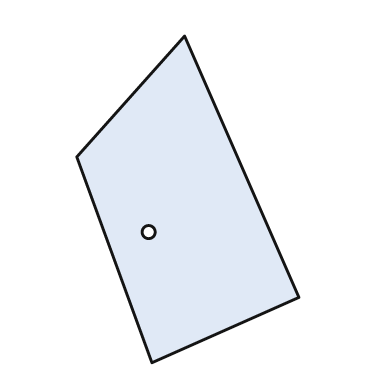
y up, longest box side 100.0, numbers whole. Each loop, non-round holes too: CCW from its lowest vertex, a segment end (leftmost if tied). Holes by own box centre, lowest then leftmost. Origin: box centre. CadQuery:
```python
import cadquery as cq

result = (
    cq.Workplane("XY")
    .moveTo(-11.0, -50.0)
    .lineTo(34.0, -30.0)
    .lineTo(-1.0, 50.0)
    .lineTo(-34.0, 13.0)
    .close()
    .moveTo(-12.0, -10.0)
    .circle(2.0)
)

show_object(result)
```